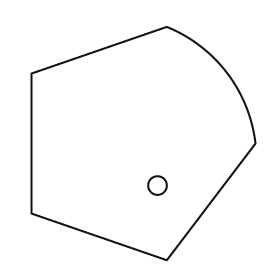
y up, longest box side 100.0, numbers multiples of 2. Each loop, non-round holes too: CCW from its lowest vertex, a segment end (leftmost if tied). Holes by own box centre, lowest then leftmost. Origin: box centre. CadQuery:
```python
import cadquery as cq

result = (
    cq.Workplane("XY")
    .moveTo(10.0, -50.0)
    .lineTo(48.0, 0.0)
    .threePointArc((36.0, 30.0), (10.0, 50.0))
    .lineTo(-48.0, 30.0)
    .lineTo(-48.0, -30.0)
    .close()
    .moveTo(6.0, -18.0)
    .circle(4.0)
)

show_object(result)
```